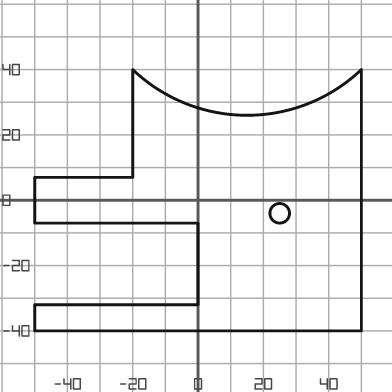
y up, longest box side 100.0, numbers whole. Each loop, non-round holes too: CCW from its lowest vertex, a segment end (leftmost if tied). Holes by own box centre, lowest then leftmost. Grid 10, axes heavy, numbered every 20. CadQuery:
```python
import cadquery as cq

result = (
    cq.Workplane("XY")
    .moveTo(-50.0, -40.0)
    .lineTo(50.0, -40.0)
    .lineTo(50.0, 40.0)
    .threePointArc((15.0, 26.0), (-20.0, 40.0))
    .lineTo(-20.0, 7.0)
    .lineTo(-50.0, 7.0)
    .lineTo(-50.0, -7.0)
    .lineTo(0.0, -7.0)
    .lineTo(0.0, -32.0)
    .lineTo(-50.0, -32.0)
    .close()
    .moveTo(25.0, -4.0)
    .circle(3.0)
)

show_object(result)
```